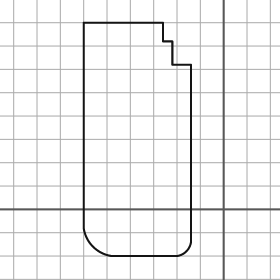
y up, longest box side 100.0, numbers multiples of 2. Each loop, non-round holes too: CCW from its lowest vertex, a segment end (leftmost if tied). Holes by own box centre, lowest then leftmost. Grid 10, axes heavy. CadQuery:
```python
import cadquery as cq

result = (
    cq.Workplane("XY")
    .moveTo(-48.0, -20.0)
    .lineTo(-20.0, -20.0)
    .threePointArc((-16.0, -18.0), (-14.0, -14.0))
    .lineTo(-14.0, 62.0)
    .lineTo(-22.0, 62.0)
    .lineTo(-22.0, 72.0)
    .lineTo(-26.0, 72.0)
    .lineTo(-26.0, 80.0)
    .lineTo(-60.0, 80.0)
    .lineTo(-60.0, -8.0)
    .threePointArc((-56.0, -16.0), (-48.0, -20.0))
    .close()
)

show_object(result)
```